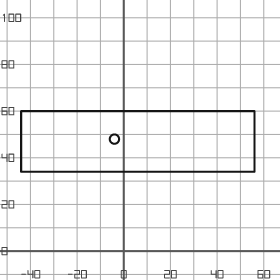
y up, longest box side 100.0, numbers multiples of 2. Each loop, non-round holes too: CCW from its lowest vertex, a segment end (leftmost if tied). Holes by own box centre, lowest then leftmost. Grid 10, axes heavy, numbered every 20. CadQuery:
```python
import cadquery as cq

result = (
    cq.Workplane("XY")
    .moveTo(-44.0, 34.0)
    .lineTo(56.0, 34.0)
    .lineTo(56.0, 60.0)
    .lineTo(-44.0, 60.0)
    .close()
    .moveTo(-4.0, 48.0)
    .circle(2.0)
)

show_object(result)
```